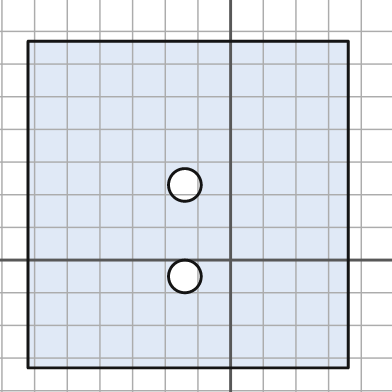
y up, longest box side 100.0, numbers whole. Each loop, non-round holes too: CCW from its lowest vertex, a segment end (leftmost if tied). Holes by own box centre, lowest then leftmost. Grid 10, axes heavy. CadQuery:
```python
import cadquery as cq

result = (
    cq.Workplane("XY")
    .moveTo(-62.0, -33.0)
    .lineTo(36.0, -33.0)
    .lineTo(36.0, 67.0)
    .lineTo(-62.0, 67.0)
    .close()
    .moveTo(-14.0, -5.0)
    .circle(5.0)
    .moveTo(-14.0, 23.0)
    .circle(5.0)
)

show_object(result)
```